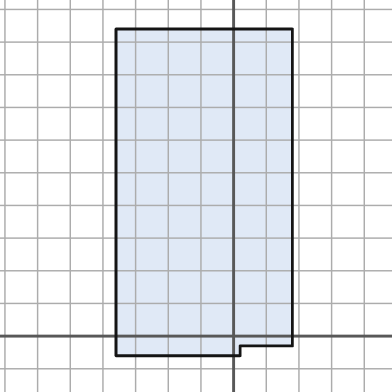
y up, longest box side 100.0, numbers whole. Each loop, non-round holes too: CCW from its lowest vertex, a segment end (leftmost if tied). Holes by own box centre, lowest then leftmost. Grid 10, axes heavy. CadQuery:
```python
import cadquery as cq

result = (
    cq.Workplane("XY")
    .moveTo(-36.0, -6.0)
    .lineTo(2.0, -6.0)
    .lineTo(2.0, -3.0)
    .lineTo(18.0, -3.0)
    .lineTo(18.0, 94.0)
    .lineTo(-36.0, 94.0)
    .close()
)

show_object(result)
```